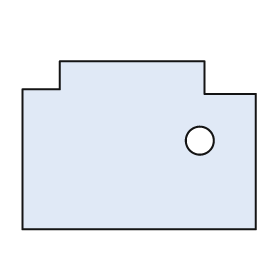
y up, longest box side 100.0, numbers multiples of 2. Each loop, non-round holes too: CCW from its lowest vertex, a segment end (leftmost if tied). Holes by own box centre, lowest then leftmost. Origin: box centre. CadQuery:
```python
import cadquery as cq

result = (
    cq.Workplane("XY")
    .moveTo(-50.0, -36.0)
    .lineTo(50.0, -36.0)
    .lineTo(50.0, 22.0)
    .lineTo(28.0, 22.0)
    .lineTo(28.0, 36.0)
    .lineTo(-34.0, 36.0)
    .lineTo(-34.0, 24.0)
    .lineTo(-50.0, 24.0)
    .close()
    .moveTo(26.0, 2.0)
    .circle(6.0)
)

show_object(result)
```